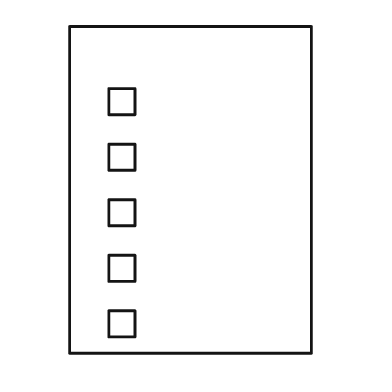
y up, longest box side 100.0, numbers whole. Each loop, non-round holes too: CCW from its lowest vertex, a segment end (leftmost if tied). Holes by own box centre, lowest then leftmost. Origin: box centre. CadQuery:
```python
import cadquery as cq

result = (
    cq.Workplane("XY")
    .moveTo(-37.0, -50.0)
    .lineTo(37.0, -50.0)
    .lineTo(37.0, 50.0)
    .lineTo(-37.0, 50.0)
    .close()
    .moveTo(-25.0, -45.0)
    .lineTo(-17.0, -45.0)
    .lineTo(-17.0, -37.0)
    .lineTo(-25.0, -37.0)
    .close()
    .moveTo(-25.0, -28.0)
    .lineTo(-17.0, -28.0)
    .lineTo(-17.0, -20.0)
    .lineTo(-25.0, -20.0)
    .close()
    .moveTo(-25.0, -11.0)
    .lineTo(-17.0, -11.0)
    .lineTo(-17.0, -3.0)
    .lineTo(-25.0, -3.0)
    .close()
    .moveTo(-25.0, 6.0)
    .lineTo(-17.0, 6.0)
    .lineTo(-17.0, 14.0)
    .lineTo(-25.0, 14.0)
    .close()
    .moveTo(-25.0, 23.0)
    .lineTo(-17.0, 23.0)
    .lineTo(-17.0, 31.0)
    .lineTo(-25.0, 31.0)
    .close()
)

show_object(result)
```